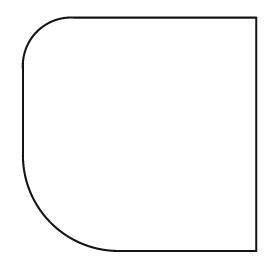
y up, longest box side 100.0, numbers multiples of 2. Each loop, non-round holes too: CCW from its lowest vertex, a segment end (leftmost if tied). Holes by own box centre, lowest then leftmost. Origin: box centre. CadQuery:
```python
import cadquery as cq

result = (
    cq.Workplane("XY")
    .moveTo(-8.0, -50.0)
    .lineTo(50.0, -50.0)
    .lineTo(50.0, 50.0)
    .lineTo(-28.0, 50.0)
    .threePointArc((-44.0, 44.0), (-50.0, 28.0))
    .lineTo(-50.0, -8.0)
    .threePointArc((-38.0, -38.0), (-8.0, -50.0))
    .close()
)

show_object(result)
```